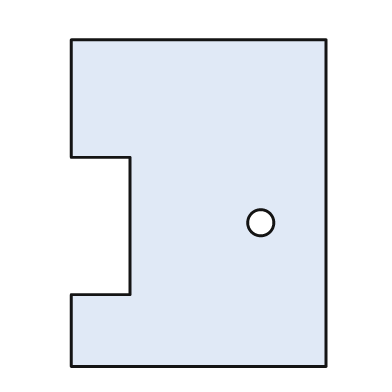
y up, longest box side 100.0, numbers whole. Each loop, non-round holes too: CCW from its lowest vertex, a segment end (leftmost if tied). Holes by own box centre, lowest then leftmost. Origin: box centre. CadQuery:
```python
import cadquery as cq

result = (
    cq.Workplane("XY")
    .moveTo(-39.0, -50.0)
    .lineTo(39.0, -50.0)
    .lineTo(39.0, 50.0)
    .lineTo(-39.0, 50.0)
    .lineTo(-39.0, 14.0)
    .lineTo(-21.0, 14.0)
    .lineTo(-21.0, -28.0)
    .lineTo(-39.0, -28.0)
    .close()
    .moveTo(19.0, -6.0)
    .circle(4.0)
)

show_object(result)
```